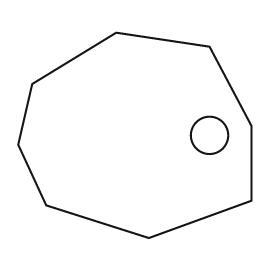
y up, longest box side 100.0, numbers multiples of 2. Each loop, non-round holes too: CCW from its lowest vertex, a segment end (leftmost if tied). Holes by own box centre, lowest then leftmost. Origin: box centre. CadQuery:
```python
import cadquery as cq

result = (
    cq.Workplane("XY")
    .moveTo(6.0, -44.0)
    .lineTo(50.0, -28.0)
    .lineTo(50.0, 4.0)
    .lineTo(32.0, 38.0)
    .lineTo(-8.0, 44.0)
    .lineTo(-44.0, 22.0)
    .lineTo(-50.0, -4.0)
    .lineTo(-38.0, -30.0)
    .close()
    .moveTo(32.0, 0.0)
    .circle(8.0)
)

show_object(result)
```